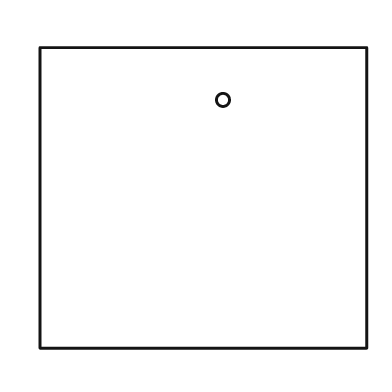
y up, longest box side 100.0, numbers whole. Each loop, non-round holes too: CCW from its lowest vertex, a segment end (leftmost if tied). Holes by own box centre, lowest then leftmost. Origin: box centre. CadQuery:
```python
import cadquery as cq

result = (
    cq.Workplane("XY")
    .moveTo(-50.0, -46.0)
    .lineTo(50.0, -46.0)
    .lineTo(50.0, 46.0)
    .lineTo(-50.0, 46.0)
    .close()
    .moveTo(6.0, 30.0)
    .circle(2.0)
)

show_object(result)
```